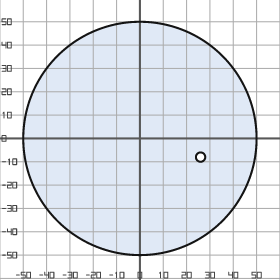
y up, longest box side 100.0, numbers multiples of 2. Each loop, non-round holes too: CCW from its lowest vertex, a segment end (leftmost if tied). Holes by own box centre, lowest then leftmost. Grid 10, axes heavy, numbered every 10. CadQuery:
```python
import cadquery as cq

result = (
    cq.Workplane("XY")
    .moveTo(0.0, 0.0)
    .circle(50.0)
    .moveTo(26.0, -8.0)
    .circle(2.0)
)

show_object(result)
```